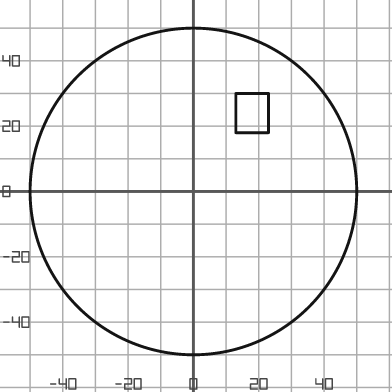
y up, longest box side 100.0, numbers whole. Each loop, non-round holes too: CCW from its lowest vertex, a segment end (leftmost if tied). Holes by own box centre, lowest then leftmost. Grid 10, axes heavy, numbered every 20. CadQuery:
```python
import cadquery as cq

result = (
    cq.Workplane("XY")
    .moveTo(0.0, 0.0)
    .circle(50.0)
    .moveTo(13.0, 18.0)
    .lineTo(23.0, 18.0)
    .lineTo(23.0, 30.0)
    .lineTo(13.0, 30.0)
    .close()
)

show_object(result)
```